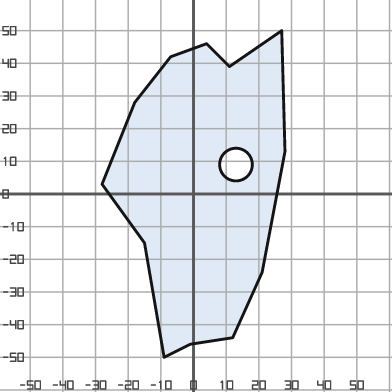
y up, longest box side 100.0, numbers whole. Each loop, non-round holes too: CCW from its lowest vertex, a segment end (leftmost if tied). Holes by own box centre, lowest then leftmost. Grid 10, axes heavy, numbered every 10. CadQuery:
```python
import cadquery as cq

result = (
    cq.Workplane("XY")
    .moveTo(-9.0, -50.0)
    .lineTo(-1.0, -46.0)
    .lineTo(12.0, -44.0)
    .lineTo(21.0, -24.0)
    .lineTo(28.0, 13.0)
    .lineTo(27.0, 50.0)
    .lineTo(11.0, 39.0)
    .lineTo(4.0, 46.0)
    .lineTo(-7.0, 42.0)
    .lineTo(-18.0, 28.0)
    .lineTo(-28.0, 3.0)
    .lineTo(-15.0, -15.0)
    .close()
    .moveTo(13.0, 9.0)
    .circle(5.0)
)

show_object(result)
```